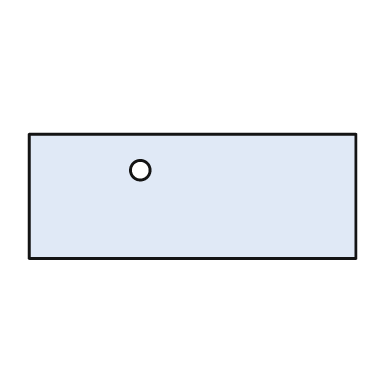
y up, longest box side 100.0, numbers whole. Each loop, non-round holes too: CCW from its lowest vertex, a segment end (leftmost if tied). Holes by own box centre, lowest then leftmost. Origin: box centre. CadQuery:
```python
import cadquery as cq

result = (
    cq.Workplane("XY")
    .moveTo(-50.0, -19.0)
    .lineTo(50.0, -19.0)
    .lineTo(50.0, 19.0)
    .lineTo(-50.0, 19.0)
    .close()
    .moveTo(-16.0, 8.0)
    .circle(3.0)
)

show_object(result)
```